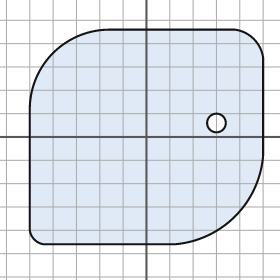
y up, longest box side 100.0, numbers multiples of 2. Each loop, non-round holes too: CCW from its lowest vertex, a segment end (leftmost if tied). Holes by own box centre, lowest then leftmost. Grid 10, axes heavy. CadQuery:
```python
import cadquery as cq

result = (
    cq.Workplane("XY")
    .moveTo(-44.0, -46.0)
    .lineTo(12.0, -46.0)
    .threePointArc((38.0, -34.0), (50.0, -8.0))
    .lineTo(50.0, 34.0)
    .threePointArc((46.0, 42.0), (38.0, 46.0))
    .lineTo(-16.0, 46.0)
    .threePointArc((-40.0, 36.0), (-50.0, 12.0))
    .lineTo(-50.0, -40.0)
    .threePointArc((-48.0, -44.0), (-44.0, -46.0))
    .close()
    .moveTo(30.0, 6.0)
    .circle(4.0)
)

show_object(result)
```